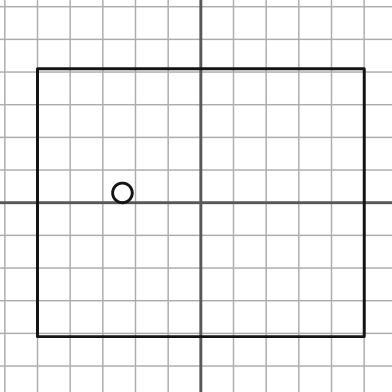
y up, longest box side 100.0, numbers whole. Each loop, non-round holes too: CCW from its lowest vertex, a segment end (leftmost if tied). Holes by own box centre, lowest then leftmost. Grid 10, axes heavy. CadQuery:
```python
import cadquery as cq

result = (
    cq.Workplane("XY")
    .moveTo(-50.0, -41.0)
    .lineTo(50.0, -41.0)
    .lineTo(50.0, 41.0)
    .lineTo(-50.0, 41.0)
    .close()
    .moveTo(-24.0, 3.0)
    .circle(3.0)
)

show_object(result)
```